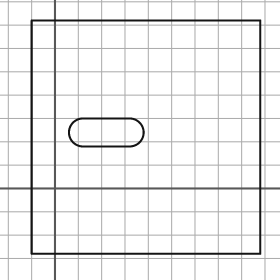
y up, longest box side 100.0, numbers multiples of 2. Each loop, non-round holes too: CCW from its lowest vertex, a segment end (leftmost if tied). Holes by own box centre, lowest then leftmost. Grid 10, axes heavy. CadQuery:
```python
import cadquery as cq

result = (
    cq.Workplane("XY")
    .moveTo(-10.0, -28.0)
    .lineTo(88.0, -28.0)
    .lineTo(88.0, 72.0)
    .lineTo(-10.0, 72.0)
    .close()
    .moveTo(12.0, 18.0)
    .lineTo(32.0, 18.0)
    .threePointArc((38.0, 24.0), (32.0, 30.0))
    .lineTo(12.0, 30.0)
    .threePointArc((6.0, 24.0), (12.0, 18.0))
    .close()
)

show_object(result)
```